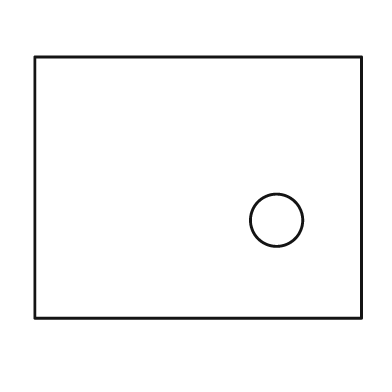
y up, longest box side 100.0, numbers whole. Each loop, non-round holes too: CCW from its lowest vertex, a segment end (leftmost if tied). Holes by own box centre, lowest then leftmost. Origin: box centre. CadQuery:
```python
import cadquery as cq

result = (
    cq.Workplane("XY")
    .moveTo(-50.0, -40.0)
    .lineTo(50.0, -40.0)
    .lineTo(50.0, 40.0)
    .lineTo(-50.0, 40.0)
    .close()
    .moveTo(24.0, -10.0)
    .circle(8.0)
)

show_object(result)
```